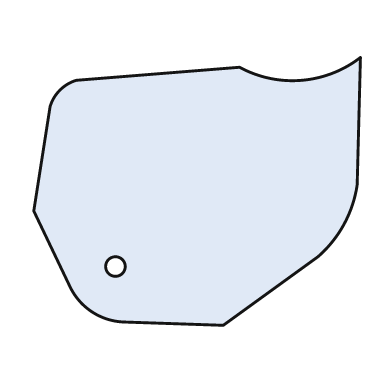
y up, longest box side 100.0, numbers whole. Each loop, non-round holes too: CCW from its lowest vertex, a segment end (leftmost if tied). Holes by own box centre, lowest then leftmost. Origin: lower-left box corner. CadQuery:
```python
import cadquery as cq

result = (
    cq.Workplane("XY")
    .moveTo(58.0, 0.0)
    .lineTo(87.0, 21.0)
    .threePointArc((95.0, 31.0), (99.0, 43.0))
    .lineTo(100.0, 82.0)
    .threePointArc((82.0, 75.0), (63.0, 79.0))
    .lineTo(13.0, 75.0)
    .threePointArc((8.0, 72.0), (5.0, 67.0))
    .lineTo(0.0, 35.0)
    .lineTo(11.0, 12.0)
    .threePointArc((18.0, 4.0), (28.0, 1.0))
    .close()
    .moveTo(25.0, 18.0)
    .circle(3.0)
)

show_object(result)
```